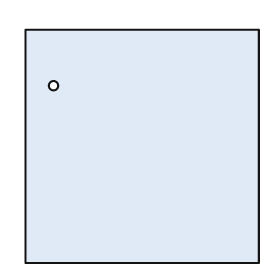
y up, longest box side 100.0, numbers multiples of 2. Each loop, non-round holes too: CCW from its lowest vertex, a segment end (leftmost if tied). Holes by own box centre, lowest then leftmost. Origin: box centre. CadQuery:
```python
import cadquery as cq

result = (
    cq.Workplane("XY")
    .moveTo(-50.0, -50.0)
    .lineTo(50.0, -50.0)
    .lineTo(50.0, 50.0)
    .lineTo(-50.0, 50.0)
    .close()
    .moveTo(-38.0, 26.0)
    .circle(2.0)
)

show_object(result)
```